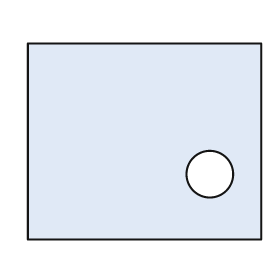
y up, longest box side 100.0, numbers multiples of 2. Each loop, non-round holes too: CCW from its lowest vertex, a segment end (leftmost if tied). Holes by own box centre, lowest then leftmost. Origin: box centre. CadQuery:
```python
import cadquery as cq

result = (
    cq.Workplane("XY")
    .moveTo(-50.0, -42.0)
    .lineTo(50.0, -42.0)
    .lineTo(50.0, 42.0)
    .lineTo(-50.0, 42.0)
    .close()
    .moveTo(28.0, -14.0)
    .circle(10.0)
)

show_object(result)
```